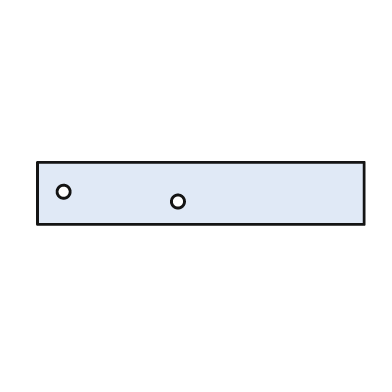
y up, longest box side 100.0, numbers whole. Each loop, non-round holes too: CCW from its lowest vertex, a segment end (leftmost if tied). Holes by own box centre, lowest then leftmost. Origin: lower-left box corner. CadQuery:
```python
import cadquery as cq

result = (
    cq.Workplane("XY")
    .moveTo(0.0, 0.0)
    .lineTo(100.0, 0.0)
    .lineTo(100.0, 19.0)
    .lineTo(0.0, 19.0)
    .close()
    .moveTo(43.0, 7.0)
    .circle(2.0)
    .moveTo(8.0, 10.0)
    .circle(2.0)
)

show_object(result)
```